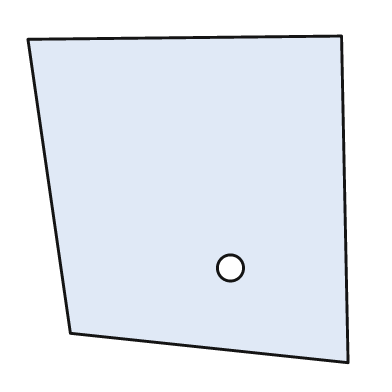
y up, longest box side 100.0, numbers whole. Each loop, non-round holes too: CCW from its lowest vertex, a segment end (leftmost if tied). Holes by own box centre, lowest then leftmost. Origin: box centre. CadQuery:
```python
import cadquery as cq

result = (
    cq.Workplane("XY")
    .moveTo(49.0, -50.0)
    .lineTo(47.0, 50.0)
    .lineTo(-49.0, 49.0)
    .lineTo(-36.0, -41.0)
    .close()
    .moveTo(13.0, -21.0)
    .circle(4.0)
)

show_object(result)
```